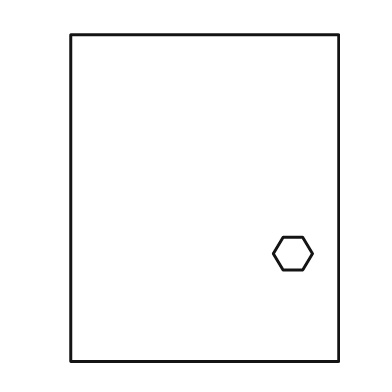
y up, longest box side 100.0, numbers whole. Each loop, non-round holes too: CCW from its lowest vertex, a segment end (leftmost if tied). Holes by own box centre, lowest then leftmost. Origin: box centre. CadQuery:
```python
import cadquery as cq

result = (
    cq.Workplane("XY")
    .moveTo(-41.0, -50.0)
    .lineTo(41.0, -50.0)
    .lineTo(41.0, 50.0)
    .lineTo(-41.0, 50.0)
    .close()
    .moveTo(24.0, -22.0)
    .lineTo(30.0, -22.0)
    .lineTo(33.0, -17.0)
    .lineTo(30.0, -12.0)
    .lineTo(24.0, -12.0)
    .lineTo(21.0, -17.0)
    .close()
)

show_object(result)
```